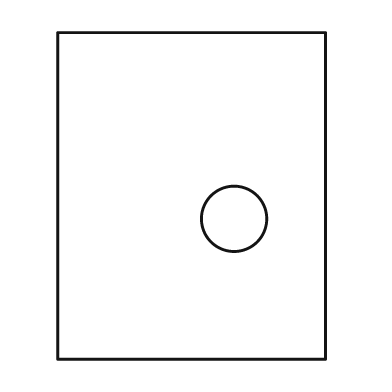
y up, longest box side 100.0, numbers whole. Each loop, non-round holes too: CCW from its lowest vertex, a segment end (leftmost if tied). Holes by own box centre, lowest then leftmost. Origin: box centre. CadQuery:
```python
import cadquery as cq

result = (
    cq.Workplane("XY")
    .moveTo(-41.0, -50.0)
    .lineTo(41.0, -50.0)
    .lineTo(41.0, 50.0)
    .lineTo(-41.0, 50.0)
    .close()
    .moveTo(13.0, -7.0)
    .circle(10.0)
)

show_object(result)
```